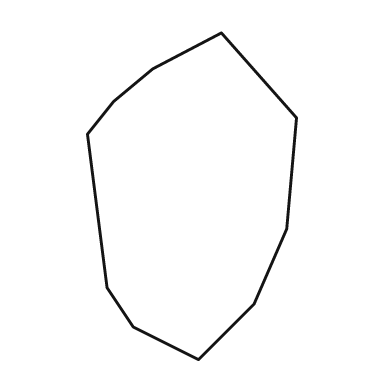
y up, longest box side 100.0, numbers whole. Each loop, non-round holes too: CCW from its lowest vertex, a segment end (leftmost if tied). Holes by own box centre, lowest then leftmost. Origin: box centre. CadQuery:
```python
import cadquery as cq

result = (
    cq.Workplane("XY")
    .moveTo(2.0, -50.0)
    .lineTo(19.0, -33.0)
    .lineTo(29.0, -10.0)
    .lineTo(32.0, 24.0)
    .lineTo(9.0, 50.0)
    .lineTo(-12.0, 39.0)
    .lineTo(-24.0, 29.0)
    .lineTo(-32.0, 19.0)
    .lineTo(-26.0, -28.0)
    .lineTo(-18.0, -40.0)
    .close()
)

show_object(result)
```